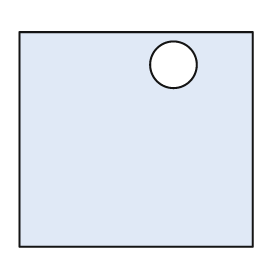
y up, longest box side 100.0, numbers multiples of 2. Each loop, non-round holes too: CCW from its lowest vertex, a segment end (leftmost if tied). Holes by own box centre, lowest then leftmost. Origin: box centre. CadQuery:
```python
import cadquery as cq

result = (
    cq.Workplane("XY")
    .moveTo(-50.0, -46.0)
    .lineTo(50.0, -46.0)
    .lineTo(50.0, 46.0)
    .lineTo(-50.0, 46.0)
    .close()
    .moveTo(16.0, 32.0)
    .circle(10.0)
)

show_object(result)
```